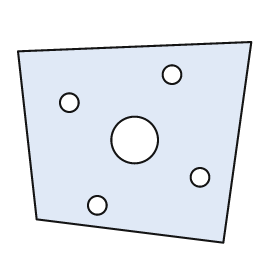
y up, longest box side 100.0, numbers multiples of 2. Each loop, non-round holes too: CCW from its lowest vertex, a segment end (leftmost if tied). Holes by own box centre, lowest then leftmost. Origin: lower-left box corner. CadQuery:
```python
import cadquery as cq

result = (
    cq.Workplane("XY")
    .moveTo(88.0, 0.0)
    .lineTo(100.0, 86.0)
    .lineTo(0.0, 82.0)
    .lineTo(8.0, 10.0)
    .close()
    .moveTo(34.0, 16.0)
    .circle(4.0)
    .moveTo(78.0, 28.0)
    .circle(4.0)
    .moveTo(50.0, 44.0)
    .circle(10.0)
    .moveTo(22.0, 60.0)
    .circle(4.0)
    .moveTo(66.0, 72.0)
    .circle(4.0)
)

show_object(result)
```